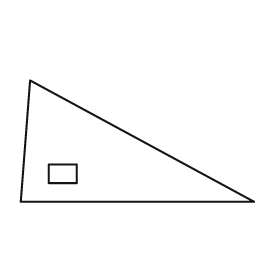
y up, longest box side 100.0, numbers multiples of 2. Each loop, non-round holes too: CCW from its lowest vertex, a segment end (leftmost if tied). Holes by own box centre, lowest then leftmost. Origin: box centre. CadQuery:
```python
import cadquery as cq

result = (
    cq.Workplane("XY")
    .moveTo(-50.0, -26.0)
    .lineTo(50.0, -26.0)
    .lineTo(-46.0, 26.0)
    .close()
    .moveTo(-38.0, -18.0)
    .lineTo(-26.0, -18.0)
    .lineTo(-26.0, -10.0)
    .lineTo(-38.0, -10.0)
    .close()
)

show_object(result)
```